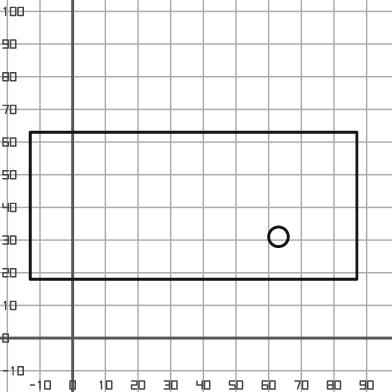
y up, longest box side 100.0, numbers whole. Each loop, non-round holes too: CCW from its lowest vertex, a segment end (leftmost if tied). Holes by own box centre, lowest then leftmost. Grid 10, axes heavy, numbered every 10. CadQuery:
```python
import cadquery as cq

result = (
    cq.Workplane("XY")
    .moveTo(-13.0, 18.0)
    .lineTo(87.0, 18.0)
    .lineTo(87.0, 63.0)
    .lineTo(-13.0, 63.0)
    .close()
    .moveTo(63.0, 31.0)
    .circle(3.0)
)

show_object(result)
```